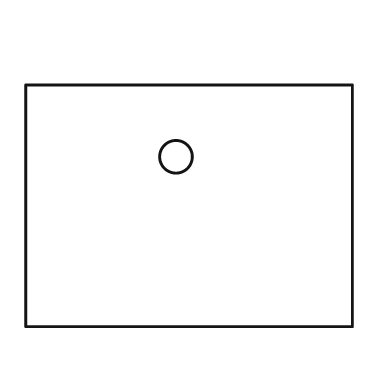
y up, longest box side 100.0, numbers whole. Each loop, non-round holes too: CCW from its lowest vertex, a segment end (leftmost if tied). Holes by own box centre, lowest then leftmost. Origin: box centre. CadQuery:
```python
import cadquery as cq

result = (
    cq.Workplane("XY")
    .moveTo(-50.0, -37.0)
    .lineTo(50.0, -37.0)
    .lineTo(50.0, 37.0)
    .lineTo(-50.0, 37.0)
    .close()
    .moveTo(-4.0, 15.0)
    .circle(5.0)
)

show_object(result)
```